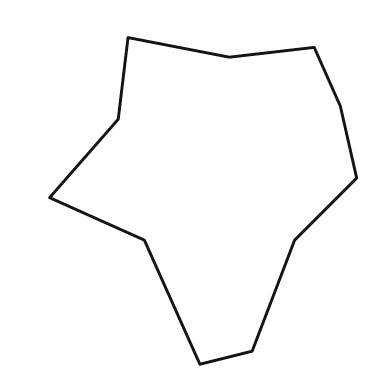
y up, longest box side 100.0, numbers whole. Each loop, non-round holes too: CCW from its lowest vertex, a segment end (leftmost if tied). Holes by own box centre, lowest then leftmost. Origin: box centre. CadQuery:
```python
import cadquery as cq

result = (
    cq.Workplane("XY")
    .moveTo(-1.0, -50.0)
    .lineTo(15.0, -46.0)
    .lineTo(28.0, -12.0)
    .lineTo(47.0, 7.0)
    .lineTo(42.0, 29.0)
    .lineTo(34.0, 47.0)
    .lineTo(8.0, 44.0)
    .lineTo(-23.0, 50.0)
    .lineTo(-26.0, 25.0)
    .lineTo(-47.0, 1.0)
    .lineTo(-18.0, -12.0)
    .close()
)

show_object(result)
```